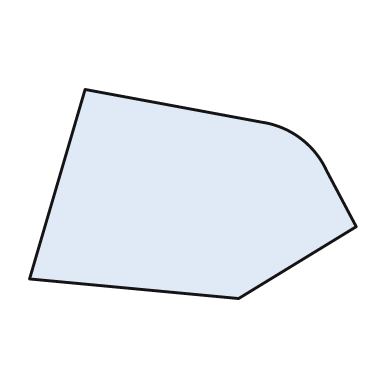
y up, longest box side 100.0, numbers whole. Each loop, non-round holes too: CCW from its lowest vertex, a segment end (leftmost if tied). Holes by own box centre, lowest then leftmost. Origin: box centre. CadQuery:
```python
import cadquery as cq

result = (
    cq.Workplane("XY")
    .moveTo(14.0, -32.0)
    .lineTo(50.0, -10.0)
    .lineTo(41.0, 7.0)
    .threePointArc((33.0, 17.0), (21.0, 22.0))
    .lineTo(-33.0, 32.0)
    .lineTo(-50.0, -26.0)
    .close()
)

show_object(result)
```